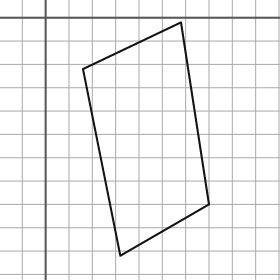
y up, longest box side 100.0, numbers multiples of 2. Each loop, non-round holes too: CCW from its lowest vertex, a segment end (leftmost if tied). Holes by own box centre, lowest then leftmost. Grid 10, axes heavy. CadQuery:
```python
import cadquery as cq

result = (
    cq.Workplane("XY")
    .moveTo(32.0, -102.0)
    .lineTo(70.0, -80.0)
    .lineTo(58.0, -2.0)
    .lineTo(16.0, -22.0)
    .close()
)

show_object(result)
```